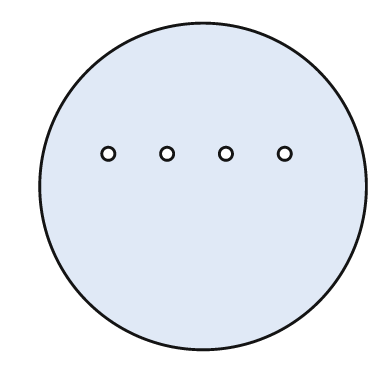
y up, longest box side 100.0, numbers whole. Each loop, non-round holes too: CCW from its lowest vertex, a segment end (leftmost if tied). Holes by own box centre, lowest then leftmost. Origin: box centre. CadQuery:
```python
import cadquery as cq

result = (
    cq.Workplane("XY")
    .moveTo(0.0, 0.0)
    .circle(50.0)
    .moveTo(-29.0, 10.0)
    .circle(2.0)
    .moveTo(-11.0, 10.0)
    .circle(2.0)
    .moveTo(7.0, 10.0)
    .circle(2.0)
    .moveTo(25.0, 10.0)
    .circle(2.0)
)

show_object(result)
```